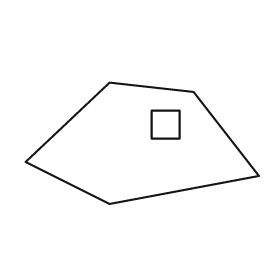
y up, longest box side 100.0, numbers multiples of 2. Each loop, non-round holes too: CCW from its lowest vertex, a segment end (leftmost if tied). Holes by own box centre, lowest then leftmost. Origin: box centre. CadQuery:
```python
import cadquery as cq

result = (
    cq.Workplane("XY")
    .moveTo(-14.0, -26.0)
    .lineTo(50.0, -14.0)
    .lineTo(22.0, 22.0)
    .lineTo(-14.0, 26.0)
    .lineTo(-50.0, -8.0)
    .close()
    .moveTo(4.0, 2.0)
    .lineTo(16.0, 2.0)
    .lineTo(16.0, 14.0)
    .lineTo(4.0, 14.0)
    .close()
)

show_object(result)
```